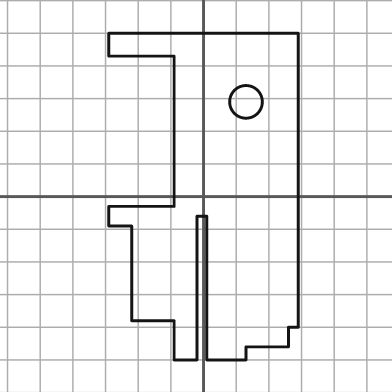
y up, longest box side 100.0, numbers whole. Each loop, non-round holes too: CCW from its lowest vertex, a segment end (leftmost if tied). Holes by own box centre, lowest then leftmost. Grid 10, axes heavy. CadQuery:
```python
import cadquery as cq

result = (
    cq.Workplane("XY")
    .moveTo(-9.0, -50.0)
    .lineTo(-2.0, -50.0)
    .lineTo(-2.0, -6.0)
    .lineTo(1.0, -6.0)
    .lineTo(1.0, -50.0)
    .lineTo(13.0, -50.0)
    .lineTo(13.0, -46.0)
    .lineTo(26.0, -46.0)
    .lineTo(26.0, -40.0)
    .lineTo(29.0, -40.0)
    .lineTo(29.0, 50.0)
    .lineTo(-29.0, 50.0)
    .lineTo(-29.0, 43.0)
    .lineTo(-9.0, 43.0)
    .lineTo(-9.0, -3.0)
    .lineTo(-29.0, -3.0)
    .lineTo(-29.0, -9.0)
    .lineTo(-22.0, -9.0)
    .lineTo(-22.0, -38.0)
    .lineTo(-9.0, -38.0)
    .close()
    .moveTo(13.0, 29.0)
    .circle(5.0)
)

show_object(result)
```